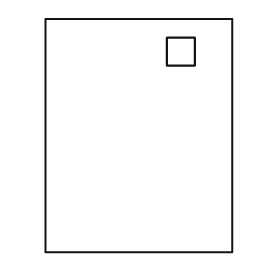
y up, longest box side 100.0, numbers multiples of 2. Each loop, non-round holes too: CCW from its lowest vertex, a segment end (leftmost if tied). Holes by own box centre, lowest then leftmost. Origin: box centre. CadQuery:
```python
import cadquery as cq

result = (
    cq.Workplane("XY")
    .moveTo(-40.0, -50.0)
    .lineTo(40.0, -50.0)
    .lineTo(40.0, 50.0)
    .lineTo(-40.0, 50.0)
    .close()
    .moveTo(12.0, 30.0)
    .lineTo(24.0, 30.0)
    .lineTo(24.0, 42.0)
    .lineTo(12.0, 42.0)
    .close()
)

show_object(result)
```